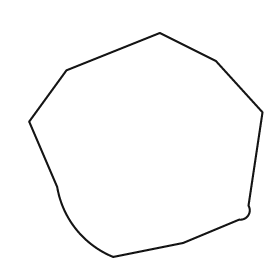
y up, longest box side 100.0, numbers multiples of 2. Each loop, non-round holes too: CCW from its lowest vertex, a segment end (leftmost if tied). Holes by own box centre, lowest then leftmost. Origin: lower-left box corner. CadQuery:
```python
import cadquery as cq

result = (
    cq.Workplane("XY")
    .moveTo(36.0, 0.0)
    .lineTo(66.0, 6.0)
    .lineTo(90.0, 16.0)
    .threePointArc((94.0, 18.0), (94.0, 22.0))
    .lineTo(100.0, 62.0)
    .lineTo(80.0, 84.0)
    .lineTo(56.0, 96.0)
    .lineTo(16.0, 80.0)
    .lineTo(0.0, 58.0)
    .lineTo(12.0, 30.0)
    .threePointArc((20.0, 12.0), (36.0, 0.0))
    .close()
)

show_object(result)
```